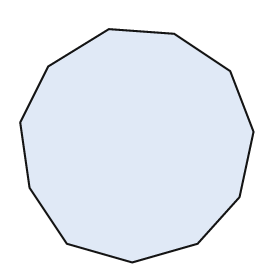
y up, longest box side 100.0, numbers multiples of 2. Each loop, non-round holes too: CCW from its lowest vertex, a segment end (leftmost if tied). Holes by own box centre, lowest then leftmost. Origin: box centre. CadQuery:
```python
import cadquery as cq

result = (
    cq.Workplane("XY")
    .moveTo(-2.0, -50.0)
    .lineTo(26.0, -42.0)
    .lineTo(44.0, -22.0)
    .lineTo(50.0, 6.0)
    .lineTo(40.0, 32.0)
    .lineTo(16.0, 48.0)
    .lineTo(-12.0, 50.0)
    .lineTo(-38.0, 34.0)
    .lineTo(-50.0, 10.0)
    .lineTo(-46.0, -18.0)
    .lineTo(-30.0, -42.0)
    .close()
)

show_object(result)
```